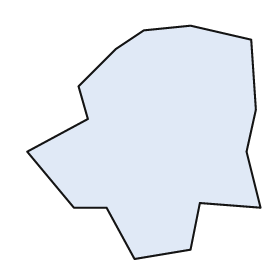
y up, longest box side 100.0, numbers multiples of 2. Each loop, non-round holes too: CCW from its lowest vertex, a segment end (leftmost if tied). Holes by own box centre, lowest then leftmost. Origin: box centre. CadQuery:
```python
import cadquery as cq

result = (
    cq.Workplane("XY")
    .moveTo(-4.0, -50.0)
    .lineTo(20.0, -46.0)
    .lineTo(24.0, -26.0)
    .lineTo(50.0, -28.0)
    .lineTo(44.0, -4.0)
    .lineTo(48.0, 14.0)
    .lineTo(46.0, 44.0)
    .lineTo(20.0, 50.0)
    .lineTo(0.0, 48.0)
    .lineTo(-12.0, 40.0)
    .lineTo(-28.0, 24.0)
    .lineTo(-24.0, 10.0)
    .lineTo(-50.0, -4.0)
    .lineTo(-30.0, -28.0)
    .lineTo(-16.0, -28.0)
    .close()
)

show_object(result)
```